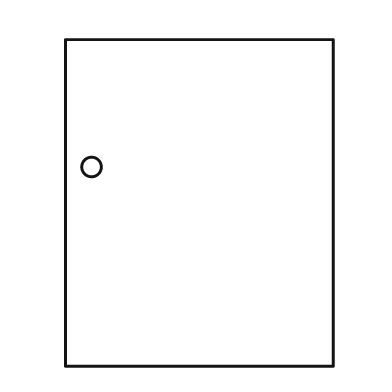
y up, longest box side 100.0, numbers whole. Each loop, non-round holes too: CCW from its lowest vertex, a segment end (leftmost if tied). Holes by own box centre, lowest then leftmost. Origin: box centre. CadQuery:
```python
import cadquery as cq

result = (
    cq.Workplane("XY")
    .moveTo(-41.0, -50.0)
    .lineTo(41.0, -50.0)
    .lineTo(41.0, 50.0)
    .lineTo(-41.0, 50.0)
    .close()
    .moveTo(-33.0, 11.0)
    .circle(3.0)
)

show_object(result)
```